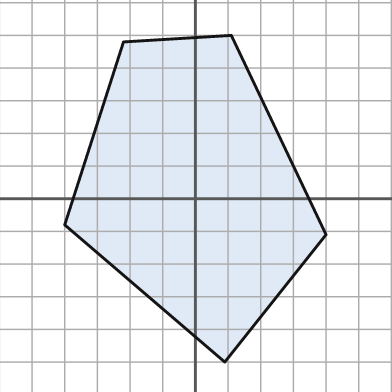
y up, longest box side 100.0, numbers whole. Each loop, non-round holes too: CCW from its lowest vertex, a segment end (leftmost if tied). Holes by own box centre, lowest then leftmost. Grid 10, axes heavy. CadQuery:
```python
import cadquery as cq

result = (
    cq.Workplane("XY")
    .moveTo(9.0, -50.0)
    .lineTo(40.0, -11.0)
    .lineTo(11.0, 50.0)
    .lineTo(-22.0, 48.0)
    .lineTo(-40.0, -8.0)
    .close()
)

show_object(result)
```